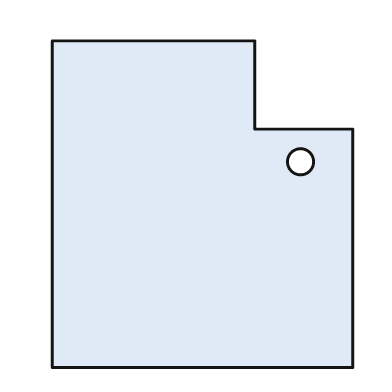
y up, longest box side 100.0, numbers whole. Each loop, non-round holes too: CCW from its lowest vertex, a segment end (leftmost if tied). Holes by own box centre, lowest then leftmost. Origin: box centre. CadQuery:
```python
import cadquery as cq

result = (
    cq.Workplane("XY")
    .moveTo(-46.0, -50.0)
    .lineTo(46.0, -50.0)
    .lineTo(46.0, 23.0)
    .lineTo(16.0, 23.0)
    .lineTo(16.0, 50.0)
    .lineTo(-46.0, 50.0)
    .close()
    .moveTo(30.0, 13.0)
    .circle(4.0)
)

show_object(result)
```